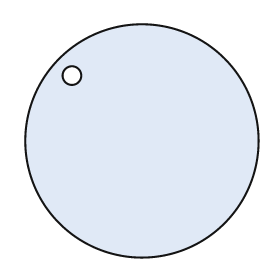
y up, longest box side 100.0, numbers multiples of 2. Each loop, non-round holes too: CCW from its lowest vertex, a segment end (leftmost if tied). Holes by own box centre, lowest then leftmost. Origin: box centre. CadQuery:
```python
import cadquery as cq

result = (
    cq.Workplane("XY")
    .moveTo(0.0, 0.0)
    .circle(50.0)
    .moveTo(-30.0, 28.0)
    .circle(4.0)
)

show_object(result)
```